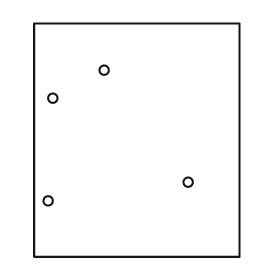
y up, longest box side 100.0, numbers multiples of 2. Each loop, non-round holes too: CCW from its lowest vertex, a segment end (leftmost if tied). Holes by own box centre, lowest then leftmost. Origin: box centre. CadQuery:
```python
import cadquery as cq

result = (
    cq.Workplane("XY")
    .moveTo(-44.0, -50.0)
    .lineTo(44.0, -50.0)
    .lineTo(44.0, 50.0)
    .lineTo(-44.0, 50.0)
    .close()
    .moveTo(-38.0, -26.0)
    .circle(2.0)
    .moveTo(22.0, -18.0)
    .circle(2.0)
    .moveTo(-36.0, 18.0)
    .circle(2.0)
    .moveTo(-14.0, 30.0)
    .circle(2.0)
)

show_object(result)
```